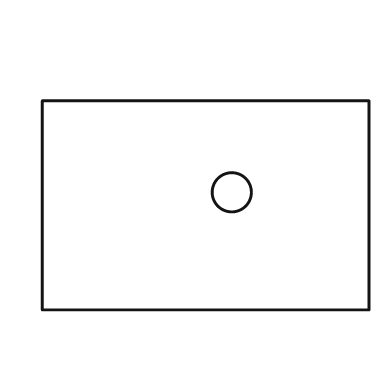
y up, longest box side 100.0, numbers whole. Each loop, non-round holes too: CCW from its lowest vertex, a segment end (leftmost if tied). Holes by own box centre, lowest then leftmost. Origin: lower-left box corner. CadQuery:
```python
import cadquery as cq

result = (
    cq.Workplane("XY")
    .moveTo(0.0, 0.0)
    .lineTo(100.0, 0.0)
    .lineTo(100.0, 64.0)
    .lineTo(0.0, 64.0)
    .close()
    .moveTo(58.0, 36.0)
    .circle(6.0)
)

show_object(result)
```